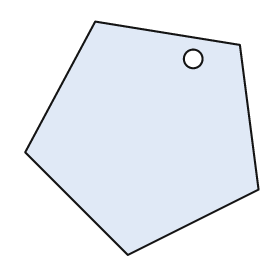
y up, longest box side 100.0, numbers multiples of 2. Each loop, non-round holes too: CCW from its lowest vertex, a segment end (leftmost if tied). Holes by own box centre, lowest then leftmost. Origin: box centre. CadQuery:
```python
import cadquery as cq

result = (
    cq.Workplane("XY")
    .moveTo(-6.0, -50.0)
    .lineTo(50.0, -22.0)
    .lineTo(42.0, 40.0)
    .lineTo(-20.0, 50.0)
    .lineTo(-50.0, -6.0)
    .close()
    .moveTo(22.0, 34.0)
    .circle(4.0)
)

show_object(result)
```